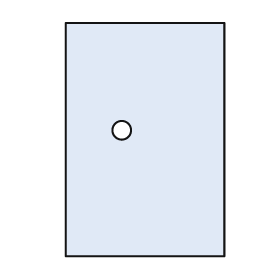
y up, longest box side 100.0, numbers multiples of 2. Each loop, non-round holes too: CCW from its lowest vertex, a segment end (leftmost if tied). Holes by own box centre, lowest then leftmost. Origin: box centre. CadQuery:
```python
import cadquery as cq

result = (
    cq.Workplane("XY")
    .moveTo(-34.0, -50.0)
    .lineTo(34.0, -50.0)
    .lineTo(34.0, 50.0)
    .lineTo(-34.0, 50.0)
    .close()
    .moveTo(-10.0, 4.0)
    .circle(4.0)
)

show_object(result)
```